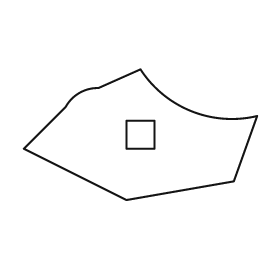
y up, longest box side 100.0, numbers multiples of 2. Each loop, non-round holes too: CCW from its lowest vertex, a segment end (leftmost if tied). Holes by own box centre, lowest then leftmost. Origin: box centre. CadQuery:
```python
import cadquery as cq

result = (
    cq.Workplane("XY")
    .moveTo(-6.0, -28.0)
    .lineTo(40.0, -20.0)
    .lineTo(50.0, 8.0)
    .threePointArc((22.0, 10.0), (0.0, 28.0))
    .lineTo(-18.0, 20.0)
    .threePointArc((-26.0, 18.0), (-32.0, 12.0))
    .lineTo(-50.0, -6.0)
    .close()
    .moveTo(-6.0, -6.0)
    .lineTo(6.0, -6.0)
    .lineTo(6.0, 6.0)
    .lineTo(-6.0, 6.0)
    .close()
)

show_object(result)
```